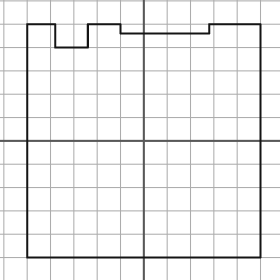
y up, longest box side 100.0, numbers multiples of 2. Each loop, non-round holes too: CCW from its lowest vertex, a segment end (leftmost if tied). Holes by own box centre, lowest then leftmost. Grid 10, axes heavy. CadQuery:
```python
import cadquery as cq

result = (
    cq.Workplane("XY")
    .moveTo(-50.0, -50.0)
    .lineTo(50.0, -50.0)
    .lineTo(50.0, 50.0)
    .lineTo(28.0, 50.0)
    .lineTo(28.0, 46.0)
    .lineTo(-10.0, 46.0)
    .lineTo(-10.0, 50.0)
    .lineTo(-24.0, 50.0)
    .lineTo(-24.0, 40.0)
    .lineTo(-38.0, 40.0)
    .lineTo(-38.0, 50.0)
    .lineTo(-50.0, 50.0)
    .close()
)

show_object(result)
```